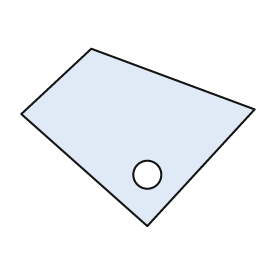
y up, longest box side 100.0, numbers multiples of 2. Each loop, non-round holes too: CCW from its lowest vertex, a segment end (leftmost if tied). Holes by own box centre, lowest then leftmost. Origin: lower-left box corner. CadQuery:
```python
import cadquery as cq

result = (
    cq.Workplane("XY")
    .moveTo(54.0, 0.0)
    .lineTo(100.0, 50.0)
    .lineTo(30.0, 76.0)
    .lineTo(0.0, 48.0)
    .close()
    .moveTo(54.0, 22.0)
    .circle(6.0)
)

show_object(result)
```